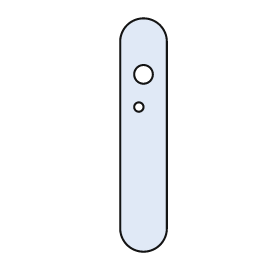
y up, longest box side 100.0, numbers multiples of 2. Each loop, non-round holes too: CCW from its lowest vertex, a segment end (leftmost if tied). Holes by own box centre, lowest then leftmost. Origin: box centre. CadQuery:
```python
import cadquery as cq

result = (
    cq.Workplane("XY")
    .moveTo(-10.0, -40.0)
    .threePointArc((0.0, -50.0), (10.0, -40.0))
    .lineTo(10.0, 40.0)
    .threePointArc((0.0, 50.0), (-10.0, 40.0))
    .close()
    .moveTo(-2.0, 12.0)
    .circle(2.0)
    .moveTo(0.0, 26.0)
    .circle(4.0)
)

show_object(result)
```